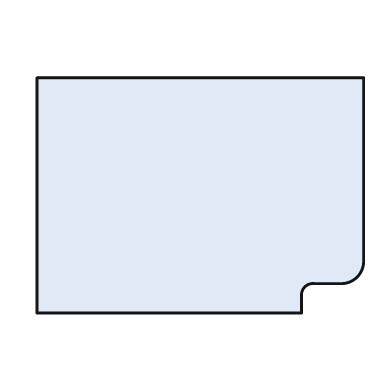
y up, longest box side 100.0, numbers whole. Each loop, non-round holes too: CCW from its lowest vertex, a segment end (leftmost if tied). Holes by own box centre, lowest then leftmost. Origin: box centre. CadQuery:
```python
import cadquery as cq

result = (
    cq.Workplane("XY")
    .moveTo(-50.0, -36.0)
    .lineTo(31.0, -36.0)
    .lineTo(31.0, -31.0)
    .threePointArc((32.0, -28.0), (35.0, -27.0))
    .lineTo(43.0, -27.0)
    .threePointArc((48.0, -25.0), (50.0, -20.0))
    .lineTo(50.0, 36.0)
    .lineTo(-50.0, 36.0)
    .close()
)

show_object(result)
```